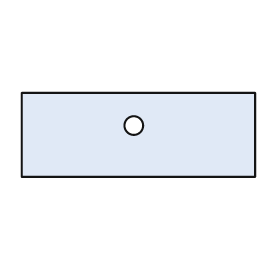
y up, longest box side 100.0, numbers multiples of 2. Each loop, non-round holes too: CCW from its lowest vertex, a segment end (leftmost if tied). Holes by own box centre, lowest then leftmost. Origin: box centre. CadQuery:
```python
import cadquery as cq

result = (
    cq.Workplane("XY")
    .moveTo(-50.0, -18.0)
    .lineTo(50.0, -18.0)
    .lineTo(50.0, 18.0)
    .lineTo(-50.0, 18.0)
    .close()
    .moveTo(-2.0, 4.0)
    .circle(4.0)
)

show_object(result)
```